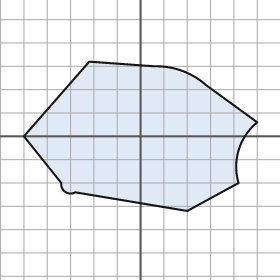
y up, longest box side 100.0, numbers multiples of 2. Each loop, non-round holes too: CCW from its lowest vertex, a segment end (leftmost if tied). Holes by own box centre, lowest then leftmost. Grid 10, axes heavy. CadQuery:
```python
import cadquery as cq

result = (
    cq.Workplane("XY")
    .moveTo(20.0, -32.0)
    .lineTo(42.0, -20.0)
    .threePointArc((42.0, -6.0), (50.0, 6.0))
    .lineTo(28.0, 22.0)
    .threePointArc((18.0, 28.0), (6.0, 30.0))
    .lineTo(-22.0, 32.0)
    .lineTo(-50.0, 0.0)
    .lineTo(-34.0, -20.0)
    .threePointArc((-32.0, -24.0), (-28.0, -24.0))
    .close()
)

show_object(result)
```